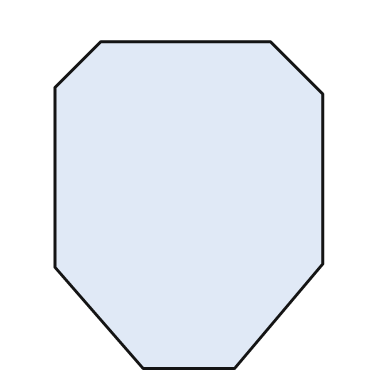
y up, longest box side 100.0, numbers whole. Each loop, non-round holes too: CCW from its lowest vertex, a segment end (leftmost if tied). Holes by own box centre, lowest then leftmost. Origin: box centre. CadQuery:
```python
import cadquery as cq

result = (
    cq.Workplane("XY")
    .moveTo(-14.0, -50.0)
    .lineTo(14.0, -50.0)
    .lineTo(41.0, -18.0)
    .lineTo(41.0, 34.0)
    .lineTo(25.0, 50.0)
    .lineTo(-27.0, 50.0)
    .lineTo(-41.0, 36.0)
    .lineTo(-41.0, -19.0)
    .close()
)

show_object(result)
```